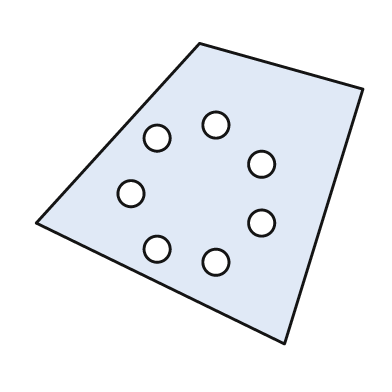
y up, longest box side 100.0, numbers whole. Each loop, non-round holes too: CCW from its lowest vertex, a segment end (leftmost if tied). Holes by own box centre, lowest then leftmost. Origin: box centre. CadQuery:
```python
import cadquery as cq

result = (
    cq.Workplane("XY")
    .moveTo(26.0, -46.0)
    .lineTo(50.0, 32.0)
    .lineTo(0.0, 46.0)
    .lineTo(-50.0, -9.0)
    .close()
    .moveTo(5.0, -21.0)
    .circle(4.0)
    .moveTo(-13.0, -17.0)
    .circle(4.0)
    .moveTo(19.0, -9.0)
    .circle(4.0)
    .moveTo(-21.0, 0.0)
    .circle(4.0)
    .moveTo(19.0, 9.0)
    .circle(4.0)
    .moveTo(-13.0, 17.0)
    .circle(4.0)
    .moveTo(5.0, 21.0)
    .circle(4.0)
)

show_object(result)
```